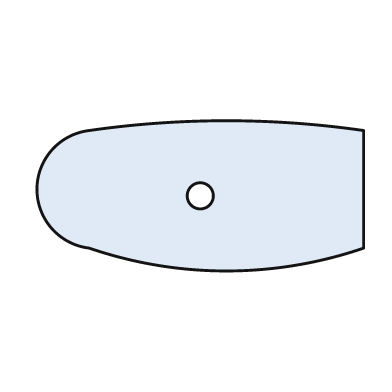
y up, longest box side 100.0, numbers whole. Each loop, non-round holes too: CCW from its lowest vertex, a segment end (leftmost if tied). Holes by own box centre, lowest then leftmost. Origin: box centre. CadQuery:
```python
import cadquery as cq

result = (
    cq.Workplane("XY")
    .moveTo(-34.0, -16.0)
    .threePointArc((8.0, -23.0), (50.0, -16.0))
    .lineTo(50.0, 20.0)
    .threePointArc((8.0, 23.0), (-34.0, 20.0))
    .threePointArc((-50.0, 2.0), (-34.0, -16.0))
    .close()
    .moveTo(0.0, 0.0)
    .circle(4.0)
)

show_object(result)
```